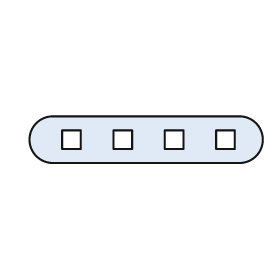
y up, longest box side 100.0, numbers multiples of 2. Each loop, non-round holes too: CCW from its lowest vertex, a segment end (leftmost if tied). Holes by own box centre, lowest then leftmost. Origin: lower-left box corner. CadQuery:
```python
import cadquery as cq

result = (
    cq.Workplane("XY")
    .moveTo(10.0, 0.0)
    .lineTo(90.0, 0.0)
    .threePointArc((100.0, 10.0), (90.0, 20.0))
    .lineTo(10.0, 20.0)
    .threePointArc((0.0, 10.0), (10.0, 0.0))
    .close()
    .moveTo(14.0, 6.0)
    .lineTo(22.0, 6.0)
    .lineTo(22.0, 14.0)
    .lineTo(14.0, 14.0)
    .close()
    .moveTo(36.0, 6.0)
    .lineTo(44.0, 6.0)
    .lineTo(44.0, 14.0)
    .lineTo(36.0, 14.0)
    .close()
    .moveTo(58.0, 6.0)
    .lineTo(66.0, 6.0)
    .lineTo(66.0, 14.0)
    .lineTo(58.0, 14.0)
    .close()
    .moveTo(80.0, 6.0)
    .lineTo(88.0, 6.0)
    .lineTo(88.0, 14.0)
    .lineTo(80.0, 14.0)
    .close()
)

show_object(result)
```